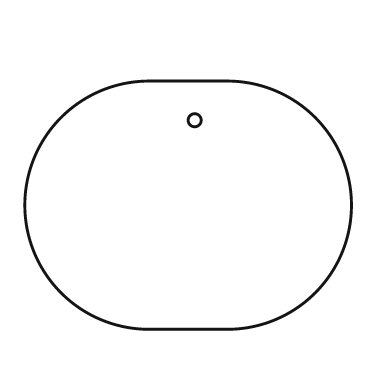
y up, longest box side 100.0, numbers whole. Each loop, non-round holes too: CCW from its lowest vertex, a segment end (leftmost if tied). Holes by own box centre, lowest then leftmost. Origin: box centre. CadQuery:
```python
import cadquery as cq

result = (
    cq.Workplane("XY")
    .moveTo(-12.0, -38.0)
    .lineTo(12.0, -38.0)
    .threePointArc((50.0, 0.0), (12.0, 38.0))
    .lineTo(-12.0, 38.0)
    .threePointArc((-50.0, 0.0), (-12.0, -38.0))
    .close()
    .moveTo(2.0, 26.0)
    .circle(2.0)
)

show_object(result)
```